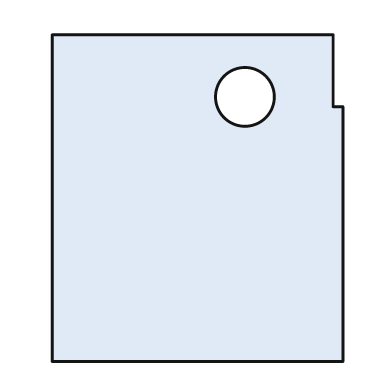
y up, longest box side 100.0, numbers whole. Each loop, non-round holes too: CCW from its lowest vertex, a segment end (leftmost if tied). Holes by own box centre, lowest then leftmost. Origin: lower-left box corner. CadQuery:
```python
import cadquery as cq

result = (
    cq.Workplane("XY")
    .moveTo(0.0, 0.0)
    .lineTo(89.0, 0.0)
    .lineTo(89.0, 78.0)
    .lineTo(86.0, 78.0)
    .lineTo(86.0, 100.0)
    .lineTo(0.0, 100.0)
    .close()
    .moveTo(59.0, 81.0)
    .circle(9.0)
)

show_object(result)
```